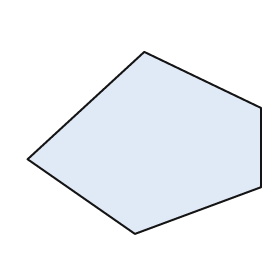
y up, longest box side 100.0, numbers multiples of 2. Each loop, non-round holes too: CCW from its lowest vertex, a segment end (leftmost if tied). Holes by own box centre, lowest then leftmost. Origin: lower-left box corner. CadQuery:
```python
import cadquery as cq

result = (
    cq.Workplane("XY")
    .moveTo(46.0, 0.0)
    .lineTo(100.0, 20.0)
    .lineTo(100.0, 54.0)
    .lineTo(50.0, 78.0)
    .lineTo(0.0, 32.0)
    .close()
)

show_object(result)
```